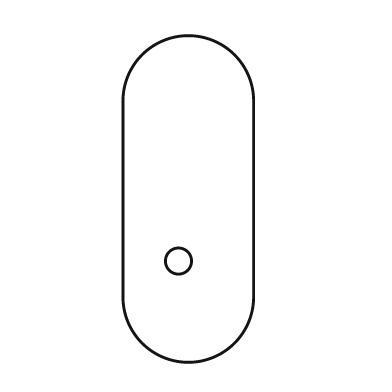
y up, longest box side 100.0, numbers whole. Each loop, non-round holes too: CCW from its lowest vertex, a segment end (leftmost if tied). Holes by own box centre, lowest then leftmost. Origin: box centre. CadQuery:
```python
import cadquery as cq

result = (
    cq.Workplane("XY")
    .moveTo(-20.0, -30.0)
    .threePointArc((0.0, -50.0), (20.0, -30.0))
    .lineTo(20.0, 30.0)
    .threePointArc((0.0, 50.0), (-20.0, 30.0))
    .close()
    .moveTo(-3.0, -19.0)
    .circle(4.0)
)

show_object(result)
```